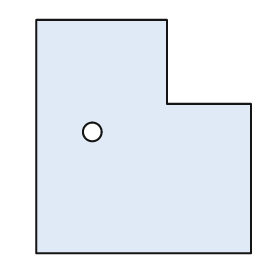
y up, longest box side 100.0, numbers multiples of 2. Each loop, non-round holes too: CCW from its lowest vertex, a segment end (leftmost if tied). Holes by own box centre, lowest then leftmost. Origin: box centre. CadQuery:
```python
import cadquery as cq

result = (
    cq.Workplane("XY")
    .moveTo(-46.0, -50.0)
    .lineTo(46.0, -50.0)
    .lineTo(46.0, 14.0)
    .lineTo(10.0, 14.0)
    .lineTo(10.0, 50.0)
    .lineTo(-46.0, 50.0)
    .close()
    .moveTo(-22.0, 2.0)
    .circle(4.0)
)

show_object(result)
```